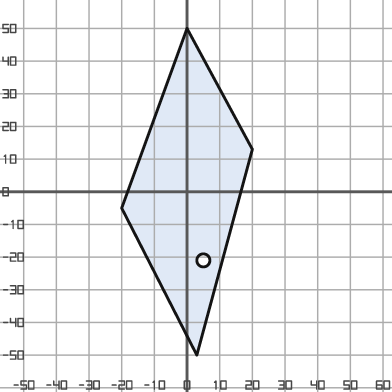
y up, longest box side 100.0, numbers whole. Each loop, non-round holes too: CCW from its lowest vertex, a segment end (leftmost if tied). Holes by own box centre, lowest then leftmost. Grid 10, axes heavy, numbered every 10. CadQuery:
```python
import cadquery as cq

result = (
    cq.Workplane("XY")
    .moveTo(3.0, -50.0)
    .lineTo(20.0, 13.0)
    .lineTo(0.0, 50.0)
    .lineTo(-20.0, -5.0)
    .close()
    .moveTo(5.0, -21.0)
    .circle(2.0)
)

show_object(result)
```